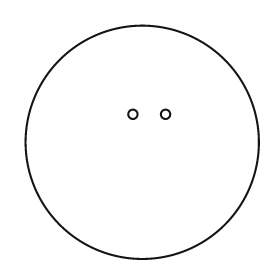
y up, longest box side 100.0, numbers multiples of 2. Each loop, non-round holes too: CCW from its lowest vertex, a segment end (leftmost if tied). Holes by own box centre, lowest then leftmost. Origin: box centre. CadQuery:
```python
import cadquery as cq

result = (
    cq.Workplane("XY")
    .moveTo(0.0, 0.0)
    .circle(50.0)
    .moveTo(-4.0, 12.0)
    .circle(2.0)
    .moveTo(10.0, 12.0)
    .circle(2.0)
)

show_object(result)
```